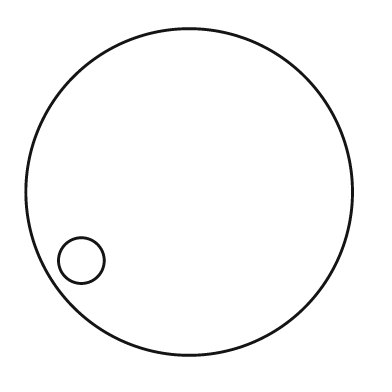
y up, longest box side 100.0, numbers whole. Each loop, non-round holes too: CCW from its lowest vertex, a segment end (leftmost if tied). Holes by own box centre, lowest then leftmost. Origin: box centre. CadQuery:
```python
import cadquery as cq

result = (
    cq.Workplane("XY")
    .moveTo(0.0, 0.0)
    .circle(50.0)
    .moveTo(-33.0, -21.0)
    .circle(7.0)
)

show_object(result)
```